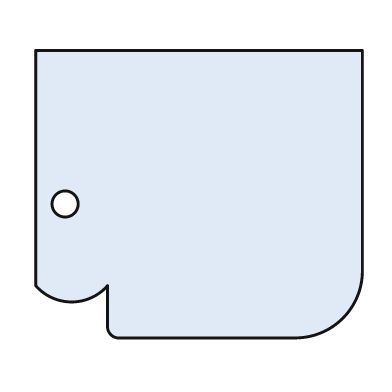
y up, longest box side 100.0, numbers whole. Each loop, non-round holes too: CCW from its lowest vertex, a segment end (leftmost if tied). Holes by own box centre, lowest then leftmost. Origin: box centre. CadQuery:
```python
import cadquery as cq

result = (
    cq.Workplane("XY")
    .moveTo(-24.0, -44.0)
    .lineTo(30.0, -44.0)
    .threePointArc((44.0, -38.0), (50.0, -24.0))
    .lineTo(50.0, 44.0)
    .lineTo(-50.0, 44.0)
    .lineTo(-50.0, -28.0)
    .threePointArc((-39.0, -33.0), (-28.0, -28.0))
    .lineTo(-28.0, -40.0)
    .threePointArc((-27.0, -43.0), (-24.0, -44.0))
    .close()
    .moveTo(-41.0, -3.0)
    .circle(4.0)
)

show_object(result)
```